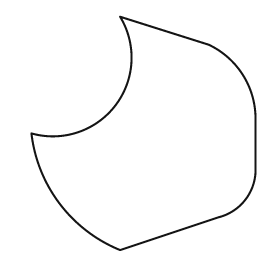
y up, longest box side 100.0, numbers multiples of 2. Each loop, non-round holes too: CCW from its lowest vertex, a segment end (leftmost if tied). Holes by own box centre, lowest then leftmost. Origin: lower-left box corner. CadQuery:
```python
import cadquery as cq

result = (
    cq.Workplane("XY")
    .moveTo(38.0, 0.0)
    .lineTo(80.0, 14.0)
    .threePointArc((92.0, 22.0), (96.0, 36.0))
    .lineTo(96.0, 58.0)
    .threePointArc((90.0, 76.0), (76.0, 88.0))
    .lineTo(38.0, 100.0)
    .threePointArc((36.0, 62.0), (0.0, 50.0))
    .threePointArc((12.0, 20.0), (38.0, 0.0))
    .close()
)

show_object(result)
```